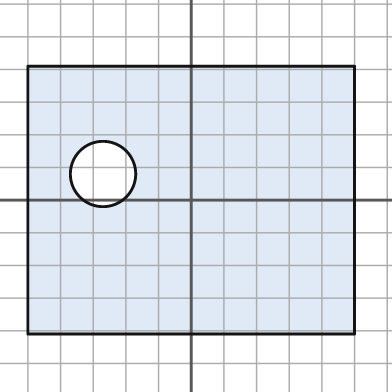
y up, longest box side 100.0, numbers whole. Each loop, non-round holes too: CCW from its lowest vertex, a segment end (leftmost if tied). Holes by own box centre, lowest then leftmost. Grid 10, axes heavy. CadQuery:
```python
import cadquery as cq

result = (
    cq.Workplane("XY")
    .moveTo(-50.0, -41.0)
    .lineTo(50.0, -41.0)
    .lineTo(50.0, 41.0)
    .lineTo(-50.0, 41.0)
    .close()
    .moveTo(-27.0, 8.0)
    .circle(10.0)
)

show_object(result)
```